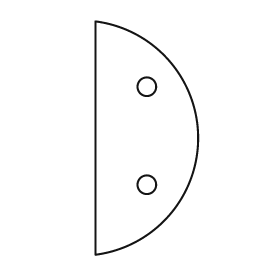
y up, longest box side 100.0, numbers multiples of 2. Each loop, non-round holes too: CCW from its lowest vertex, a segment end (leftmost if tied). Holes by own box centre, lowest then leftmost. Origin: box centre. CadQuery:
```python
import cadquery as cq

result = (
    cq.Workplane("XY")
    .moveTo(-22.0, -50.0)
    .threePointArc((22.0, 0.0), (-22.0, 50.0))
    .close()
    .moveTo(0.0, -20.0)
    .circle(4.0)
    .moveTo(0.0, 22.0)
    .circle(4.0)
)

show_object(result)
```